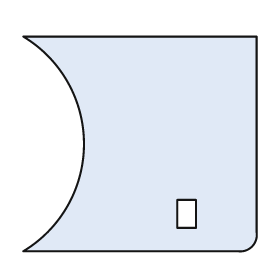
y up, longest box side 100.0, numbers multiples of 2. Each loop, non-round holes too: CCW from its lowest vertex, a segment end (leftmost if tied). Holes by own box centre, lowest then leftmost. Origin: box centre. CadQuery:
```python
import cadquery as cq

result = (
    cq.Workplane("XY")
    .moveTo(-50.0, -46.0)
    .lineTo(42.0, -46.0)
    .threePointArc((48.0, -44.0), (50.0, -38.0))
    .lineTo(50.0, 46.0)
    .lineTo(-50.0, 46.0)
    .threePointArc((-24.0, 0.0), (-50.0, -46.0))
    .close()
    .moveTo(16.0, -36.0)
    .lineTo(24.0, -36.0)
    .lineTo(24.0, -24.0)
    .lineTo(16.0, -24.0)
    .close()
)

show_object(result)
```